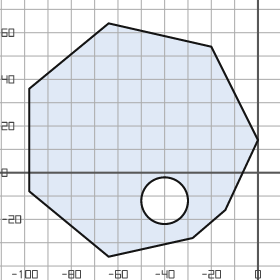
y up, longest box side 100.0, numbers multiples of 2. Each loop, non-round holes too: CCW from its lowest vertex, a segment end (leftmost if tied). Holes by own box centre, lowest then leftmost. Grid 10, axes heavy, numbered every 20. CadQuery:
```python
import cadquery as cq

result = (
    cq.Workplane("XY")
    .moveTo(-64.0, -36.0)
    .lineTo(-28.0, -28.0)
    .lineTo(-14.0, -16.0)
    .lineTo(0.0, 14.0)
    .lineTo(-20.0, 54.0)
    .lineTo(-64.0, 64.0)
    .lineTo(-98.0, 36.0)
    .lineTo(-98.0, -8.0)
    .close()
    .moveTo(-40.0, -12.0)
    .circle(10.0)
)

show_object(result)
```